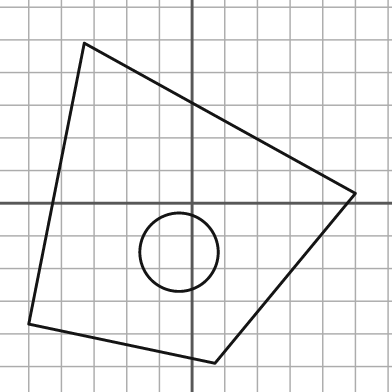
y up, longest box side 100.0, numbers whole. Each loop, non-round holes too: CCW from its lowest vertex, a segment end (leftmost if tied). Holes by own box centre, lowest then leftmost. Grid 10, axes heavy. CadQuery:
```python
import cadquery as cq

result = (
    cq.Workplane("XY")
    .moveTo(7.0, -49.0)
    .lineTo(50.0, 3.0)
    .lineTo(-33.0, 49.0)
    .lineTo(-50.0, -37.0)
    .close()
    .moveTo(-4.0, -15.0)
    .circle(12.0)
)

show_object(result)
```